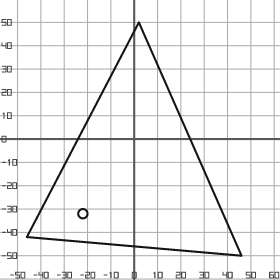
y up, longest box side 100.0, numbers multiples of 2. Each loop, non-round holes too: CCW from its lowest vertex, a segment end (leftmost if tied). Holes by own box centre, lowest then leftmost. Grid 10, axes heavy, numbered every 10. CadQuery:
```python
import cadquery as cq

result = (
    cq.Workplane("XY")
    .moveTo(46.0, -50.0)
    .lineTo(2.0, 50.0)
    .lineTo(-46.0, -42.0)
    .close()
    .moveTo(-22.0, -32.0)
    .circle(2.0)
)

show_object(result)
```